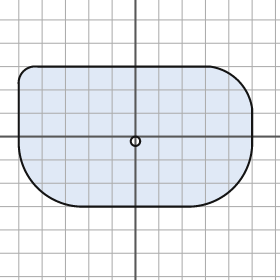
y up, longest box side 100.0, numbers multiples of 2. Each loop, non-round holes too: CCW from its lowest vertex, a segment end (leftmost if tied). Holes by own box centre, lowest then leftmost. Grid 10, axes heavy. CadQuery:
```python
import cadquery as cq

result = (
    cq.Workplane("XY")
    .moveTo(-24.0, -30.0)
    .lineTo(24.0, -30.0)
    .threePointArc((42.0, -22.0), (50.0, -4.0))
    .lineTo(50.0, 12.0)
    .threePointArc((44.0, 24.0), (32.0, 30.0))
    .lineTo(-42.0, 30.0)
    .threePointArc((-48.0, 28.0), (-50.0, 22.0))
    .lineTo(-50.0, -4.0)
    .threePointArc((-42.0, -22.0), (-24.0, -30.0))
    .close()
    .moveTo(0.0, -2.0)
    .circle(2.0)
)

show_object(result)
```